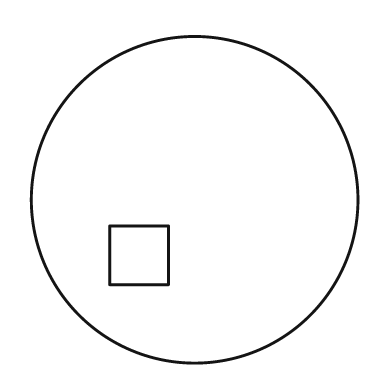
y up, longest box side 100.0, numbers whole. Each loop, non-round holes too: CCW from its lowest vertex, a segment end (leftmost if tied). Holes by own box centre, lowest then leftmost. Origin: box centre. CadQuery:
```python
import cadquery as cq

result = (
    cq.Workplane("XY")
    .moveTo(0.0, 0.0)
    .circle(50.0)
    .moveTo(-26.0, -26.0)
    .lineTo(-8.0, -26.0)
    .lineTo(-8.0, -8.0)
    .lineTo(-26.0, -8.0)
    .close()
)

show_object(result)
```